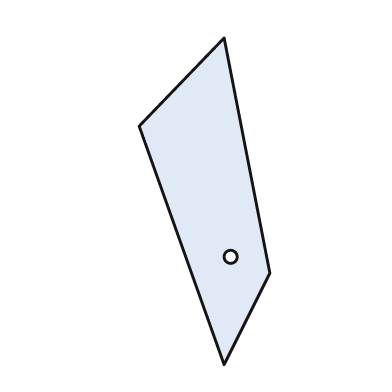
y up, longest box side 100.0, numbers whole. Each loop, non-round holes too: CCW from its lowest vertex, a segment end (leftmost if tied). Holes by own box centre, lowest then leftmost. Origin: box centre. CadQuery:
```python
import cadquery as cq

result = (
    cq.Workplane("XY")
    .moveTo(6.0, -50.0)
    .lineTo(20.0, -22.0)
    .lineTo(6.0, 50.0)
    .lineTo(-20.0, 23.0)
    .close()
    .moveTo(8.0, -17.0)
    .circle(2.0)
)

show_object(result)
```